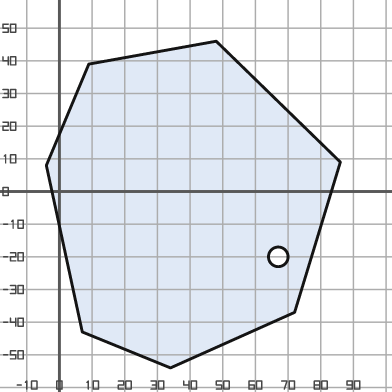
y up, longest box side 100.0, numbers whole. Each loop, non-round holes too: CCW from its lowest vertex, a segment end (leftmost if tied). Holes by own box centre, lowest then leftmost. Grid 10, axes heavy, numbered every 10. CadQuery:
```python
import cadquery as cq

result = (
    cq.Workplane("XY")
    .moveTo(34.0, -54.0)
    .lineTo(72.0, -37.0)
    .lineTo(86.0, 9.0)
    .lineTo(48.0, 46.0)
    .lineTo(9.0, 39.0)
    .lineTo(-4.0, 8.0)
    .lineTo(7.0, -43.0)
    .close()
    .moveTo(67.0, -20.0)
    .circle(3.0)
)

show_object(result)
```